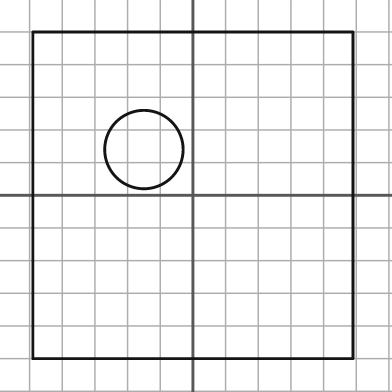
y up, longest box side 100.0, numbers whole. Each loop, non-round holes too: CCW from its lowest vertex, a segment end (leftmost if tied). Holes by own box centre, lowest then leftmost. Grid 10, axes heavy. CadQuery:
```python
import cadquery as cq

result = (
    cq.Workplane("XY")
    .moveTo(-49.0, -50.0)
    .lineTo(49.0, -50.0)
    .lineTo(49.0, 50.0)
    .lineTo(-49.0, 50.0)
    .close()
    .moveTo(-15.0, 14.0)
    .circle(12.0)
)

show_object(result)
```